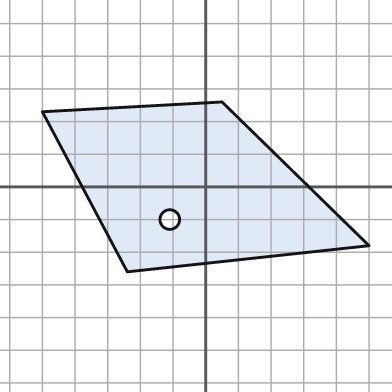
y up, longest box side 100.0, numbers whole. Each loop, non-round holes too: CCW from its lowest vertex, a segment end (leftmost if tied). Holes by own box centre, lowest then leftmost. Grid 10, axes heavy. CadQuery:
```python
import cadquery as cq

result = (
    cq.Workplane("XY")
    .moveTo(-24.0, -26.0)
    .lineTo(50.0, -18.0)
    .lineTo(5.0, 26.0)
    .lineTo(-50.0, 23.0)
    .close()
    .moveTo(-11.0, -10.0)
    .circle(3.0)
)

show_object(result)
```